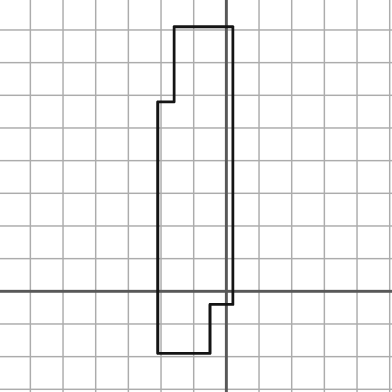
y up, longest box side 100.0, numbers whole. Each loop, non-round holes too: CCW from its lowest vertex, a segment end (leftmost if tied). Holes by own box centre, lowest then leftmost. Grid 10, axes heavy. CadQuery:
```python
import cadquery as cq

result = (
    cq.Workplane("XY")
    .moveTo(-21.0, -19.0)
    .lineTo(-5.0, -19.0)
    .lineTo(-5.0, -4.0)
    .lineTo(2.0, -4.0)
    .lineTo(2.0, 81.0)
    .lineTo(-16.0, 81.0)
    .lineTo(-16.0, 58.0)
    .lineTo(-21.0, 58.0)
    .close()
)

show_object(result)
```